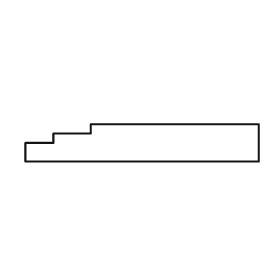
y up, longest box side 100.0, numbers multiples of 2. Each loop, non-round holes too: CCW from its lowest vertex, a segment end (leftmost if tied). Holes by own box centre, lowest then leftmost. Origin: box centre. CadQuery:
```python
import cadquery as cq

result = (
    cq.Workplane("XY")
    .moveTo(-50.0, -8.0)
    .lineTo(50.0, -8.0)
    .lineTo(50.0, 8.0)
    .lineTo(-22.0, 8.0)
    .lineTo(-22.0, 4.0)
    .lineTo(-38.0, 4.0)
    .lineTo(-38.0, 0.0)
    .lineTo(-50.0, 0.0)
    .close()
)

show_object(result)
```